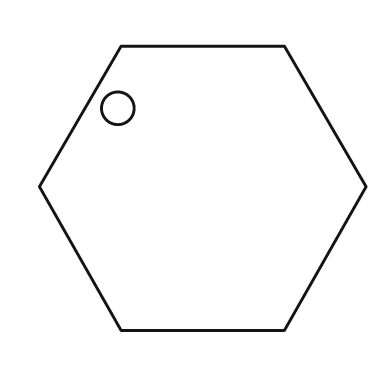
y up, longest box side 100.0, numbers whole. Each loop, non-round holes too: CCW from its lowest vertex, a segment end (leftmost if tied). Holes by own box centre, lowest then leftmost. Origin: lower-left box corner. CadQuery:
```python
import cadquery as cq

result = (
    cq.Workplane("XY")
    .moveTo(25.0, 0.0)
    .lineTo(75.0, 0.0)
    .lineTo(100.0, 44.0)
    .lineTo(75.0, 87.0)
    .lineTo(25.0, 87.0)
    .lineTo(0.0, 44.0)
    .close()
    .moveTo(24.0, 68.0)
    .circle(5.0)
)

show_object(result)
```